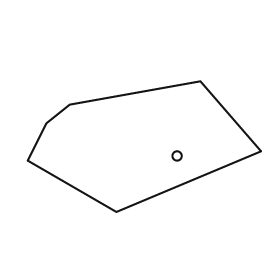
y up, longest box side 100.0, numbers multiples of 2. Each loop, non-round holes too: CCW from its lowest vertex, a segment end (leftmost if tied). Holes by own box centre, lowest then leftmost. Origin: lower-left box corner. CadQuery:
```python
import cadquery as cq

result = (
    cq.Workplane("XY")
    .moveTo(38.0, 0.0)
    .lineTo(100.0, 26.0)
    .lineTo(74.0, 56.0)
    .lineTo(18.0, 46.0)
    .lineTo(8.0, 38.0)
    .lineTo(0.0, 22.0)
    .close()
    .moveTo(64.0, 24.0)
    .circle(2.0)
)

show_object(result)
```